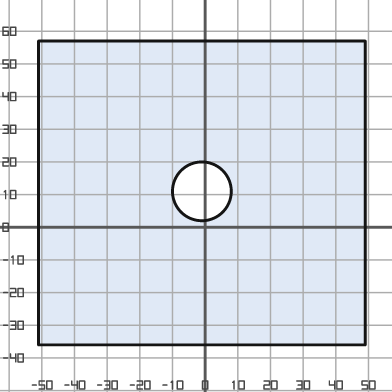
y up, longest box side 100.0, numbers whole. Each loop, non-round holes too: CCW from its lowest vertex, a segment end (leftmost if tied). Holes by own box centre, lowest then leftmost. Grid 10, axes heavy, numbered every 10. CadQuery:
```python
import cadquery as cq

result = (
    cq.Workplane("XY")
    .moveTo(-51.0, -36.0)
    .lineTo(49.0, -36.0)
    .lineTo(49.0, 57.0)
    .lineTo(-51.0, 57.0)
    .close()
    .moveTo(-1.0, 11.0)
    .circle(9.0)
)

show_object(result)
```